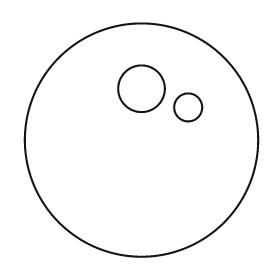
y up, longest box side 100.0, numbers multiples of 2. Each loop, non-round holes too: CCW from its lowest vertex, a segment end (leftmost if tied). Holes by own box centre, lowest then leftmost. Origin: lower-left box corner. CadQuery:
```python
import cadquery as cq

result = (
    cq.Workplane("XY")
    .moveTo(50.0, 50.0)
    .circle(50.0)
    .moveTo(70.0, 64.0)
    .circle(6.0)
    .moveTo(50.0, 72.0)
    .circle(10.0)
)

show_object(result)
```